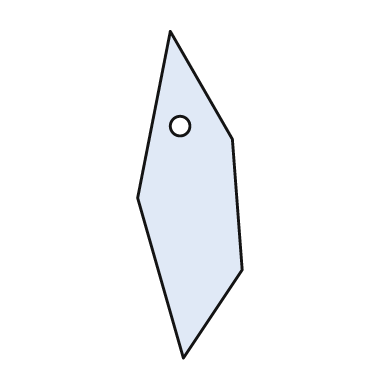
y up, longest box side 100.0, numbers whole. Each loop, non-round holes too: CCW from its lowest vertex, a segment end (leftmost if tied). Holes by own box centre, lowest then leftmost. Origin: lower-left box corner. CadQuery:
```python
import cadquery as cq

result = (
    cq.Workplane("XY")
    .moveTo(14.0, 0.0)
    .lineTo(32.0, 27.0)
    .lineTo(29.0, 67.0)
    .lineTo(10.0, 100.0)
    .lineTo(0.0, 49.0)
    .close()
    .moveTo(13.0, 71.0)
    .circle(3.0)
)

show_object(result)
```